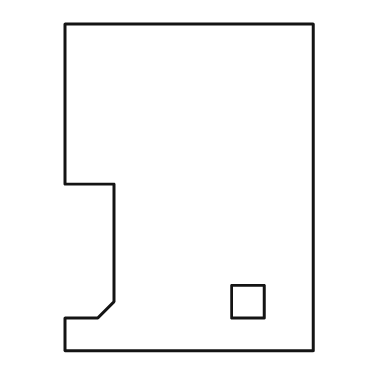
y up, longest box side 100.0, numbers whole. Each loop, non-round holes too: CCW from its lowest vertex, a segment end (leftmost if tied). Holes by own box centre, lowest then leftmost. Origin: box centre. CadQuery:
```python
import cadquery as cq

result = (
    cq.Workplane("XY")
    .moveTo(-38.0, -50.0)
    .lineTo(38.0, -50.0)
    .lineTo(38.0, 50.0)
    .lineTo(-38.0, 50.0)
    .lineTo(-38.0, 1.0)
    .lineTo(-23.0, 1.0)
    .lineTo(-23.0, -35.0)
    .lineTo(-28.0, -40.0)
    .lineTo(-38.0, -40.0)
    .close()
    .moveTo(13.0, -40.0)
    .lineTo(23.0, -40.0)
    .lineTo(23.0, -30.0)
    .lineTo(13.0, -30.0)
    .close()
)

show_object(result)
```